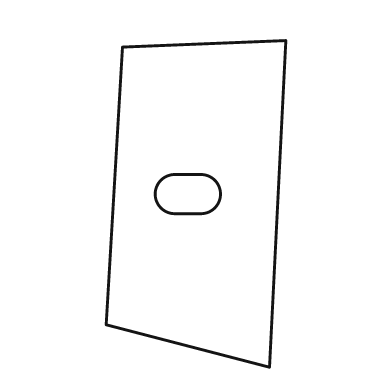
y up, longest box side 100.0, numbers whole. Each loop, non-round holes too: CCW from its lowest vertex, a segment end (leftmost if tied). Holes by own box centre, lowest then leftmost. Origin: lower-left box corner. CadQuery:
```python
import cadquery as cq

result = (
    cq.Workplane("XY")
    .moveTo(50.0, 0.0)
    .lineTo(55.0, 100.0)
    .lineTo(5.0, 98.0)
    .lineTo(0.0, 13.0)
    .close()
    .moveTo(21.0, 47.0)
    .lineTo(29.0, 47.0)
    .threePointArc((35.0, 53.0), (29.0, 59.0))
    .lineTo(21.0, 59.0)
    .threePointArc((15.0, 53.0), (21.0, 47.0))
    .close()
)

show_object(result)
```